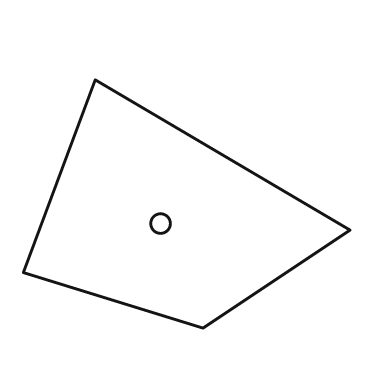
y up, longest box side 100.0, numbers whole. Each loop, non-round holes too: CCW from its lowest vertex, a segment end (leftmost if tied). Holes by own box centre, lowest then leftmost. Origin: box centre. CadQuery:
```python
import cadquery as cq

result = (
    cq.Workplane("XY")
    .moveTo(5.0, -38.0)
    .lineTo(50.0, -8.0)
    .lineTo(-28.0, 38.0)
    .lineTo(-50.0, -21.0)
    .close()
    .moveTo(-8.0, -6.0)
    .circle(3.0)
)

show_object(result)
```